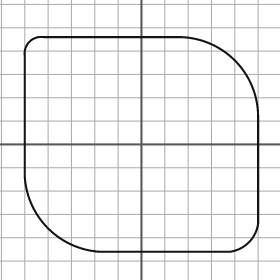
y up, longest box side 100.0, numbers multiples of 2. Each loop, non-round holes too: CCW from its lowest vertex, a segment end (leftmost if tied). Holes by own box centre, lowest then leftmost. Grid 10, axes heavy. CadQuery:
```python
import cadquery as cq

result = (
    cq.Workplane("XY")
    .moveTo(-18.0, -46.0)
    .lineTo(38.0, -46.0)
    .threePointArc((46.0, -42.0), (50.0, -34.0))
    .lineTo(50.0, 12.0)
    .threePointArc((40.0, 36.0), (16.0, 46.0))
    .lineTo(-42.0, 46.0)
    .threePointArc((-48.0, 44.0), (-50.0, 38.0))
    .lineTo(-50.0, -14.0)
    .threePointArc((-40.0, -36.0), (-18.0, -46.0))
    .close()
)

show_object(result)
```